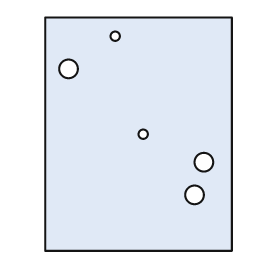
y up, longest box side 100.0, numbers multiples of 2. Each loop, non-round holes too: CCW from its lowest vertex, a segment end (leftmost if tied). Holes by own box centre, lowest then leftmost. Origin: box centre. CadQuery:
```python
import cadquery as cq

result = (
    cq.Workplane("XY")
    .moveTo(-40.0, -50.0)
    .lineTo(40.0, -50.0)
    .lineTo(40.0, 50.0)
    .lineTo(-40.0, 50.0)
    .close()
    .moveTo(24.0, -26.0)
    .circle(4.0)
    .moveTo(28.0, -12.0)
    .circle(4.0)
    .moveTo(2.0, 0.0)
    .circle(2.0)
    .moveTo(-30.0, 28.0)
    .circle(4.0)
    .moveTo(-10.0, 42.0)
    .circle(2.0)
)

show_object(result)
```